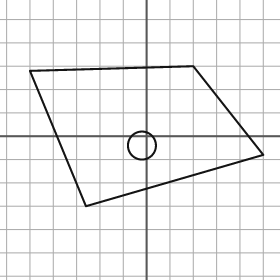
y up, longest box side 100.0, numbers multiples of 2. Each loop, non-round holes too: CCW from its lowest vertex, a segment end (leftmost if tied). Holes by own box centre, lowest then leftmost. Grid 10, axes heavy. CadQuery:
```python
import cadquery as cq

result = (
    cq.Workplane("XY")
    .moveTo(-26.0, -30.0)
    .lineTo(50.0, -8.0)
    .lineTo(20.0, 30.0)
    .lineTo(-50.0, 28.0)
    .close()
    .moveTo(-2.0, -4.0)
    .circle(6.0)
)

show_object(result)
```